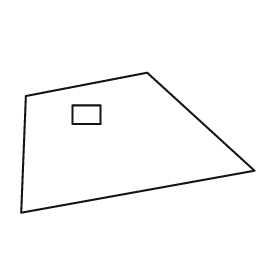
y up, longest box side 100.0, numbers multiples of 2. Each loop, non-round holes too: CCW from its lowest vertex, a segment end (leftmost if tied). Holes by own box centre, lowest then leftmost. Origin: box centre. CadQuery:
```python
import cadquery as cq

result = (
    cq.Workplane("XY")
    .moveTo(-50.0, -30.0)
    .lineTo(50.0, -12.0)
    .lineTo(4.0, 30.0)
    .lineTo(-48.0, 20.0)
    .close()
    .moveTo(-28.0, 8.0)
    .lineTo(-16.0, 8.0)
    .lineTo(-16.0, 16.0)
    .lineTo(-28.0, 16.0)
    .close()
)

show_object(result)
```